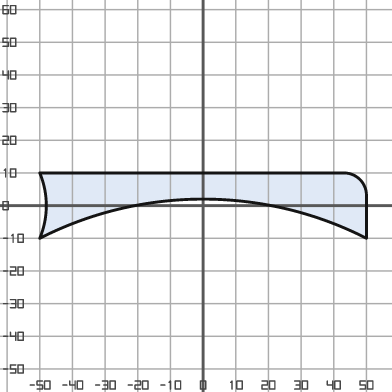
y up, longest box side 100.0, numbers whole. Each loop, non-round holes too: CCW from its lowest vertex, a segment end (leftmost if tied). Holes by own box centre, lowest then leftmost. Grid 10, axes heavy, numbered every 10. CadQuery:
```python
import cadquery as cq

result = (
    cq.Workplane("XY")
    .moveTo(-50.0, -10.0)
    .threePointArc((0.0, 2.0), (50.0, -10.0))
    .lineTo(50.0, 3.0)
    .threePointArc((48.0, 8.0), (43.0, 10.0))
    .lineTo(-50.0, 10.0)
    .threePointArc((-48.0, 0.0), (-50.0, -10.0))
    .close()
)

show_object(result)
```